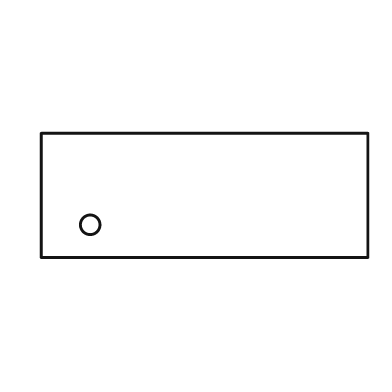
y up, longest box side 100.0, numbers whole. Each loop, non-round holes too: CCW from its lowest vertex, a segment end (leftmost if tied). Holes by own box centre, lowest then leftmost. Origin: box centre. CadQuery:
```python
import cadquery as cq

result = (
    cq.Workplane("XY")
    .moveTo(-50.0, -19.0)
    .lineTo(50.0, -19.0)
    .lineTo(50.0, 19.0)
    .lineTo(-50.0, 19.0)
    .close()
    .moveTo(-35.0, -9.0)
    .circle(3.0)
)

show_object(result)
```